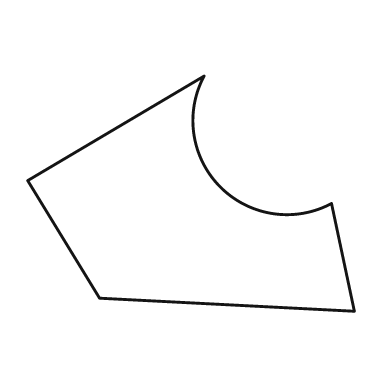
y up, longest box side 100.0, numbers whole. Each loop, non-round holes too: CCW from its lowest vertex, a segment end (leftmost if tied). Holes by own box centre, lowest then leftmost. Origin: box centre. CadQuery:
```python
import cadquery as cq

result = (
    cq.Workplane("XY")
    .moveTo(50.0, -36.0)
    .lineTo(43.0, -3.0)
    .threePointArc((9.0, 2.0), (4.0, 36.0))
    .lineTo(-50.0, 4.0)
    .lineTo(-28.0, -32.0)
    .close()
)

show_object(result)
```